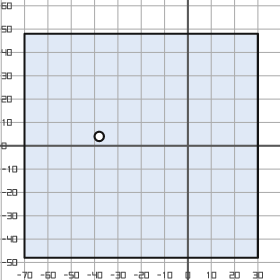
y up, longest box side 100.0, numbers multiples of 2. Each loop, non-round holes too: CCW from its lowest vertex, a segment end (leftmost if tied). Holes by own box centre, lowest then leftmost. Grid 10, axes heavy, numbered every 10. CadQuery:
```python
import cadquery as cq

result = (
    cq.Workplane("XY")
    .moveTo(-70.0, -48.0)
    .lineTo(30.0, -48.0)
    .lineTo(30.0, 48.0)
    .lineTo(-70.0, 48.0)
    .close()
    .moveTo(-38.0, 4.0)
    .circle(2.0)
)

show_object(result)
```